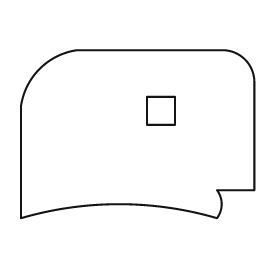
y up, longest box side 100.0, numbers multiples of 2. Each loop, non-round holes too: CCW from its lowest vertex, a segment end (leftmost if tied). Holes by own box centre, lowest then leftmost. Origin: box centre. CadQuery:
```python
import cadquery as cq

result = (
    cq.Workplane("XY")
    .moveTo(-50.0, -36.0)
    .threePointArc((-8.0, -30.0), (34.0, -36.0))
    .threePointArc((36.0, -30.0), (34.0, -24.0))
    .lineTo(50.0, -24.0)
    .lineTo(50.0, 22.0)
    .threePointArc((46.0, 32.0), (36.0, 36.0))
    .lineTo(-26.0, 36.0)
    .threePointArc((-42.0, 28.0), (-50.0, 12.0))
    .close()
    .moveTo(4.0, 4.0)
    .lineTo(16.0, 4.0)
    .lineTo(16.0, 16.0)
    .lineTo(4.0, 16.0)
    .close()
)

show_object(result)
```